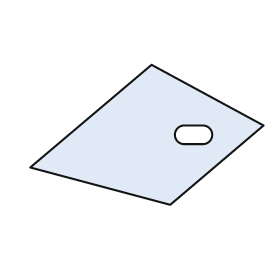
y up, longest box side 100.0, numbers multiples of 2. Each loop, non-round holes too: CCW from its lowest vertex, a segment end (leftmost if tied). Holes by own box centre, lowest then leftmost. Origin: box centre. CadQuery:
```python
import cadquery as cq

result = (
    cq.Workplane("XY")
    .moveTo(10.0, -30.0)
    .lineTo(50.0, 4.0)
    .lineTo(2.0, 30.0)
    .lineTo(-50.0, -14.0)
    .close()
    .moveTo(16.0, -4.0)
    .lineTo(24.0, -4.0)
    .threePointArc((28.0, 0.0), (24.0, 4.0))
    .lineTo(16.0, 4.0)
    .threePointArc((12.0, 0.0), (16.0, -4.0))
    .close()
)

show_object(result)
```